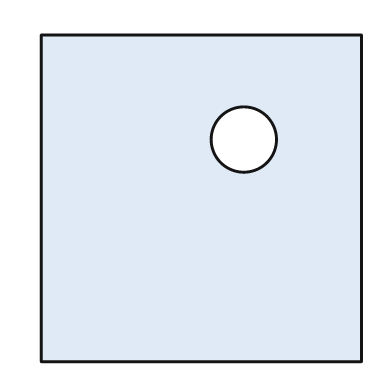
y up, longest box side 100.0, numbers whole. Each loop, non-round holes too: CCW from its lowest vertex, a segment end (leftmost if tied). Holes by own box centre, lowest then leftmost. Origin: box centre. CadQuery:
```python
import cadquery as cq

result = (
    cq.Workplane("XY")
    .moveTo(-49.0, -50.0)
    .lineTo(49.0, -50.0)
    .lineTo(49.0, 50.0)
    .lineTo(-49.0, 50.0)
    .close()
    .moveTo(13.0, 18.0)
    .circle(10.0)
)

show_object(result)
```